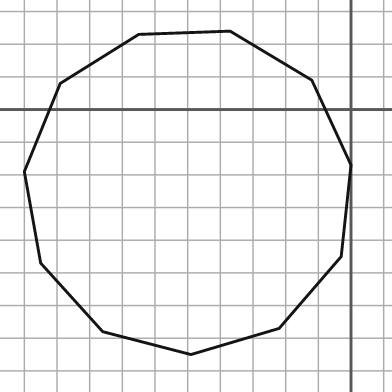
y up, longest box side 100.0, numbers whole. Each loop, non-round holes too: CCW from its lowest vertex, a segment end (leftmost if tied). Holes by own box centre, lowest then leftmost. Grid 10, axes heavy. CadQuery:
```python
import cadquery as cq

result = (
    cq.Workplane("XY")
    .moveTo(-49.0, -75.0)
    .lineTo(-22.0, -67.0)
    .lineTo(-3.0, -45.0)
    .lineTo(0.0, -17.0)
    .lineTo(-12.0, 9.0)
    .lineTo(-37.0, 24.0)
    .lineTo(-65.0, 23.0)
    .lineTo(-89.0, 8.0)
    .lineTo(-100.0, -19.0)
    .lineTo(-95.0, -47.0)
    .lineTo(-76.0, -68.0)
    .close()
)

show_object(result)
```